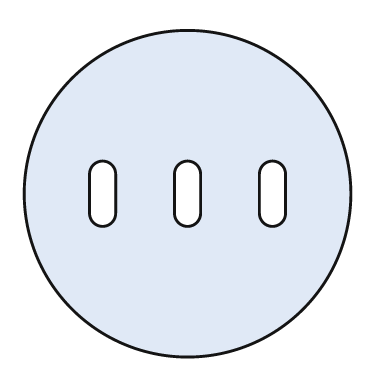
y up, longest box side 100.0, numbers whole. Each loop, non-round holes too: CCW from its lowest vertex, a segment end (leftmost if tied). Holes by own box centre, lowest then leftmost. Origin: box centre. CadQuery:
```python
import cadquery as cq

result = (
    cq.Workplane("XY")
    .moveTo(0.0, 0.0)
    .circle(50.0)
    .moveTo(-30.0, -6.0)
    .threePointArc((-26.0, -10.0), (-22.0, -6.0))
    .lineTo(-22.0, 6.0)
    .threePointArc((-26.0, 10.0), (-30.0, 6.0))
    .close()
    .moveTo(-4.0, -6.0)
    .threePointArc((0.0, -10.0), (4.0, -6.0))
    .lineTo(4.0, 6.0)
    .threePointArc((0.0, 10.0), (-4.0, 6.0))
    .close()
    .moveTo(22.0, -6.0)
    .threePointArc((26.0, -10.0), (30.0, -6.0))
    .lineTo(30.0, 6.0)
    .threePointArc((26.0, 10.0), (22.0, 6.0))
    .close()
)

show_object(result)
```